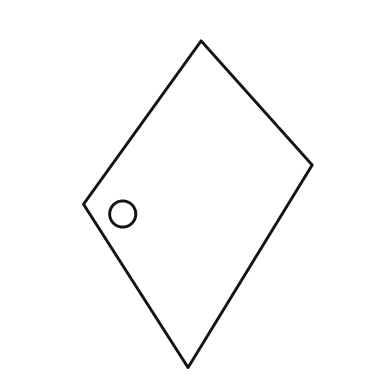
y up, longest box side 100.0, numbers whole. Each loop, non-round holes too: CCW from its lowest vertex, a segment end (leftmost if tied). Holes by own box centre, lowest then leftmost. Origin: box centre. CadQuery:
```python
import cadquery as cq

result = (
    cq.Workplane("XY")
    .moveTo(-3.0, -50.0)
    .lineTo(35.0, 12.0)
    .lineTo(1.0, 50.0)
    .lineTo(-35.0, 0.0)
    .close()
    .moveTo(-23.0, -3.0)
    .circle(4.0)
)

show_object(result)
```